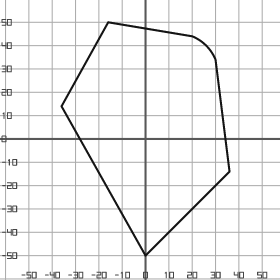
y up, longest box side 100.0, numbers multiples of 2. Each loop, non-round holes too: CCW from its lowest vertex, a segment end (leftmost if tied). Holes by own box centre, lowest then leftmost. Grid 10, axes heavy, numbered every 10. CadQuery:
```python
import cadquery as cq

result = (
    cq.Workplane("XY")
    .moveTo(0.0, -50.0)
    .lineTo(36.0, -14.0)
    .lineTo(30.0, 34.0)
    .threePointArc((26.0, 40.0), (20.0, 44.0))
    .lineTo(-16.0, 50.0)
    .lineTo(-36.0, 14.0)
    .close()
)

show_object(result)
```